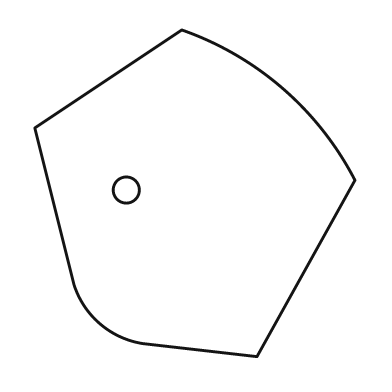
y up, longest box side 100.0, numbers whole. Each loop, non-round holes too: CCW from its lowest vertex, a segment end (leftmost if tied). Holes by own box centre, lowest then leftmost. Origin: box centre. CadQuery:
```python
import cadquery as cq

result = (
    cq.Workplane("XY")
    .moveTo(19.0, -50.0)
    .lineTo(49.0, 4.0)
    .threePointArc((27.0, 32.0), (-4.0, 50.0))
    .lineTo(-49.0, 20.0)
    .lineTo(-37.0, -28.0)
    .threePointArc((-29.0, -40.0), (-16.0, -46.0))
    .close()
    .moveTo(-21.0, 1.0)
    .circle(4.0)
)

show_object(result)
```